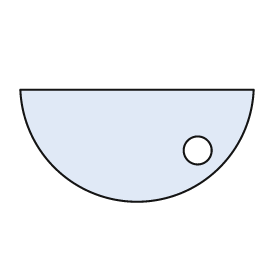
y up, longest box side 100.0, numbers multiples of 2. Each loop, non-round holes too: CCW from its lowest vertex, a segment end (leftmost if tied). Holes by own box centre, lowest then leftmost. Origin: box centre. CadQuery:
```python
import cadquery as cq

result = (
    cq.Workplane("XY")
    .moveTo(-50.0, 24.0)
    .threePointArc((0.0, -24.0), (50.0, 24.0))
    .close()
    .moveTo(26.0, -2.0)
    .circle(6.0)
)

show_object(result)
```